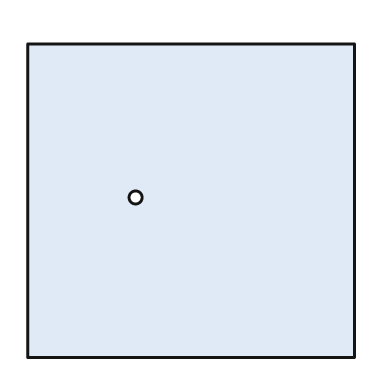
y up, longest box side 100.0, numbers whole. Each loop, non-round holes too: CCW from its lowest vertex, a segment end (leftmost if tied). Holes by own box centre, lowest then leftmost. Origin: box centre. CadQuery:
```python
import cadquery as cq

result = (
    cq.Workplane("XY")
    .moveTo(-50.0, -48.0)
    .lineTo(50.0, -48.0)
    .lineTo(50.0, 48.0)
    .lineTo(-50.0, 48.0)
    .close()
    .moveTo(-17.0, 1.0)
    .circle(2.0)
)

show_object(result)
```